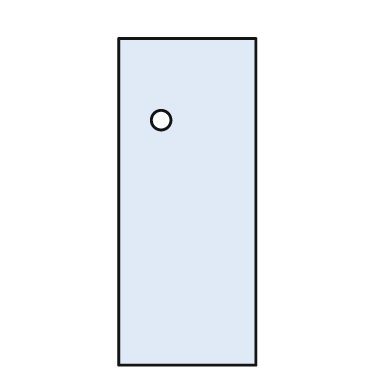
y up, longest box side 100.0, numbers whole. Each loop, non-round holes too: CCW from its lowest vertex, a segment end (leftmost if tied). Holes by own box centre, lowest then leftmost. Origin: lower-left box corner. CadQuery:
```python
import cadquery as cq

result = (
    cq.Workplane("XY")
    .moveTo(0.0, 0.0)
    .lineTo(42.0, 0.0)
    .lineTo(42.0, 100.0)
    .lineTo(0.0, 100.0)
    .close()
    .moveTo(13.0, 75.0)
    .circle(3.0)
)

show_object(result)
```